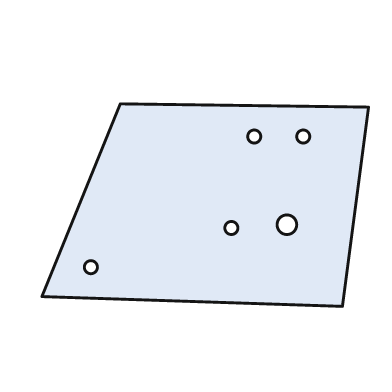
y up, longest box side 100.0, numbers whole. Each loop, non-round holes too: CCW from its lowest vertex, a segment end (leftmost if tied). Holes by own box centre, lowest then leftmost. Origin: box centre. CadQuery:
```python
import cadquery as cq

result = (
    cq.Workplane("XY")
    .moveTo(42.0, -31.0)
    .lineTo(50.0, 30.0)
    .lineTo(-26.0, 31.0)
    .lineTo(-50.0, -28.0)
    .close()
    .moveTo(-35.0, -19.0)
    .circle(2.0)
    .moveTo(8.0, -7.0)
    .circle(2.0)
    .moveTo(25.0, -6.0)
    .circle(3.0)
    .moveTo(15.0, 21.0)
    .circle(2.0)
    .moveTo(30.0, 21.0)
    .circle(2.0)
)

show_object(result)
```